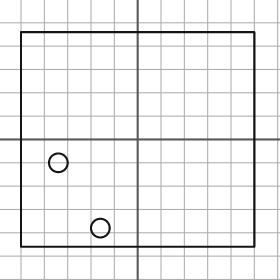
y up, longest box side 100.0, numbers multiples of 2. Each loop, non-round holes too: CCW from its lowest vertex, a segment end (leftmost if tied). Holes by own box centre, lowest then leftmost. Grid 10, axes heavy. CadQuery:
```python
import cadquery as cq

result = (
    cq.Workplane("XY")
    .moveTo(-50.0, -46.0)
    .lineTo(50.0, -46.0)
    .lineTo(50.0, 46.0)
    .lineTo(-50.0, 46.0)
    .close()
    .moveTo(-16.0, -38.0)
    .circle(4.0)
    .moveTo(-34.0, -10.0)
    .circle(4.0)
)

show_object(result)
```